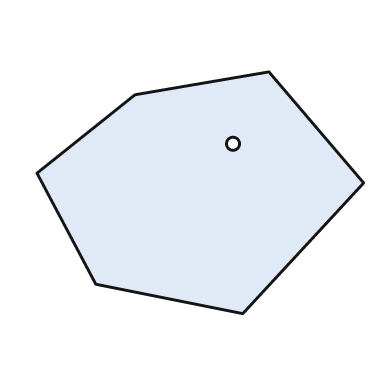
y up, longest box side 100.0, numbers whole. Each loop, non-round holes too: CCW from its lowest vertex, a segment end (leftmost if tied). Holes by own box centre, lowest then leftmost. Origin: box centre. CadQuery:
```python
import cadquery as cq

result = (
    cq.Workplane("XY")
    .moveTo(13.0, -37.0)
    .lineTo(50.0, 3.0)
    .lineTo(21.0, 37.0)
    .lineTo(-20.0, 30.0)
    .lineTo(-50.0, 6.0)
    .lineTo(-32.0, -28.0)
    .close()
    .moveTo(10.0, 15.0)
    .circle(2.0)
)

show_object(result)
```